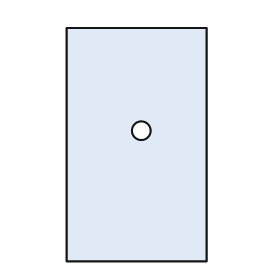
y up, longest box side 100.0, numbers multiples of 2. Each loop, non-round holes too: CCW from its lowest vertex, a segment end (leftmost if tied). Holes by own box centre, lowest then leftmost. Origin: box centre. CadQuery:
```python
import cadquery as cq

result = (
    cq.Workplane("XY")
    .moveTo(-30.0, -50.0)
    .lineTo(30.0, -50.0)
    .lineTo(30.0, 50.0)
    .lineTo(-30.0, 50.0)
    .close()
    .moveTo(2.0, 6.0)
    .circle(4.0)
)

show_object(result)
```